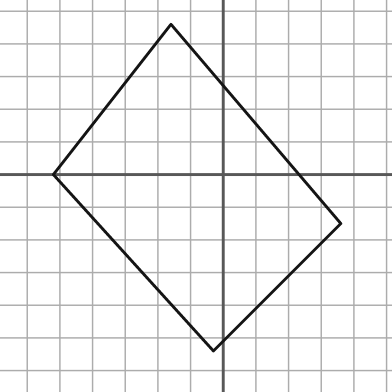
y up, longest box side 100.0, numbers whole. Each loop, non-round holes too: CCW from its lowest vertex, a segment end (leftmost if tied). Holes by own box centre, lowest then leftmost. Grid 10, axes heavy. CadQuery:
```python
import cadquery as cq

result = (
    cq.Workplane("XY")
    .moveTo(-3.0, -54.0)
    .lineTo(36.0, -15.0)
    .lineTo(-16.0, 46.0)
    .lineTo(-52.0, 0.0)
    .close()
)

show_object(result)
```